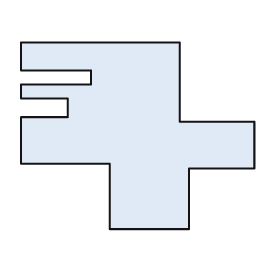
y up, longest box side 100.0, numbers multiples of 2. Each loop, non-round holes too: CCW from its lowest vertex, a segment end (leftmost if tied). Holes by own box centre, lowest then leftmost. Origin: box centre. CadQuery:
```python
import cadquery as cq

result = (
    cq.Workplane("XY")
    .moveTo(-12.0, -40.0)
    .lineTo(22.0, -40.0)
    .lineTo(22.0, -14.0)
    .lineTo(50.0, -14.0)
    .lineTo(50.0, 6.0)
    .lineTo(18.0, 6.0)
    .lineTo(18.0, 40.0)
    .lineTo(-50.0, 40.0)
    .lineTo(-50.0, 28.0)
    .lineTo(-20.0, 28.0)
    .lineTo(-20.0, 22.0)
    .lineTo(-50.0, 22.0)
    .lineTo(-50.0, 16.0)
    .lineTo(-30.0, 16.0)
    .lineTo(-30.0, 8.0)
    .lineTo(-50.0, 8.0)
    .lineTo(-50.0, -12.0)
    .lineTo(-12.0, -12.0)
    .close()
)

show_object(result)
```